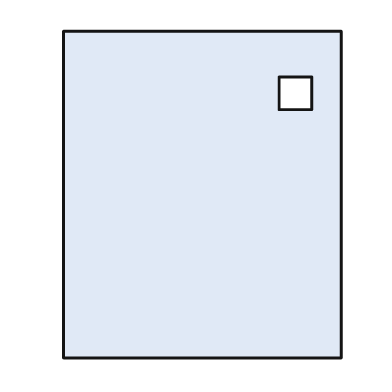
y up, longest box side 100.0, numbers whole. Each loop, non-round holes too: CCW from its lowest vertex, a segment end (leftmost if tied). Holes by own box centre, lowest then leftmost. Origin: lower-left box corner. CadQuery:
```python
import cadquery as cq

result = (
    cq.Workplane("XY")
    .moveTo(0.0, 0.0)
    .lineTo(85.0, 0.0)
    .lineTo(85.0, 100.0)
    .lineTo(0.0, 100.0)
    .close()
    .moveTo(66.0, 76.0)
    .lineTo(76.0, 76.0)
    .lineTo(76.0, 86.0)
    .lineTo(66.0, 86.0)
    .close()
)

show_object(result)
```